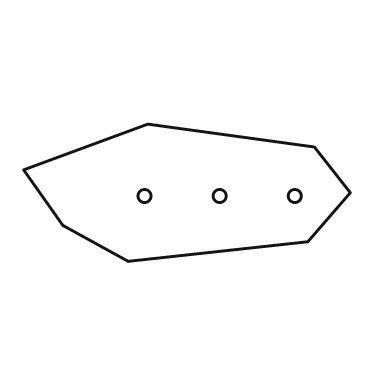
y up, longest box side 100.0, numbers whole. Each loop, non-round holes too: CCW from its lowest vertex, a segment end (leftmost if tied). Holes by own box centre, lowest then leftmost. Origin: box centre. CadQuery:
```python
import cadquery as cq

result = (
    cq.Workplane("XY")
    .moveTo(-18.0, -21.0)
    .lineTo(37.0, -15.0)
    .lineTo(50.0, 0.0)
    .lineTo(39.0, 14.0)
    .lineTo(-12.0, 21.0)
    .lineTo(-50.0, 7.0)
    .lineTo(-38.0, -10.0)
    .close()
    .moveTo(-13.0, -1.0)
    .circle(2.0)
    .moveTo(10.0, -1.0)
    .circle(2.0)
    .moveTo(33.0, -1.0)
    .circle(2.0)
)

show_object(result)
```